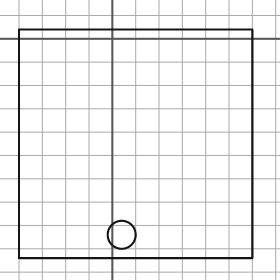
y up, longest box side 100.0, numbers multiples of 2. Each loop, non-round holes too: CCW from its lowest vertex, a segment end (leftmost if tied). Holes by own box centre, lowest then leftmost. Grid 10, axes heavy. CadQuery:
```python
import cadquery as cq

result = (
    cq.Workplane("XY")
    .moveTo(-40.0, -94.0)
    .lineTo(60.0, -94.0)
    .lineTo(60.0, 4.0)
    .lineTo(-40.0, 4.0)
    .close()
    .moveTo(4.0, -84.0)
    .circle(6.0)
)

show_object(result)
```